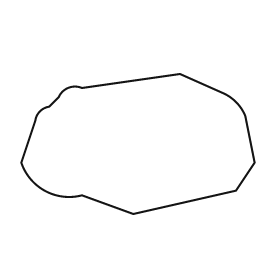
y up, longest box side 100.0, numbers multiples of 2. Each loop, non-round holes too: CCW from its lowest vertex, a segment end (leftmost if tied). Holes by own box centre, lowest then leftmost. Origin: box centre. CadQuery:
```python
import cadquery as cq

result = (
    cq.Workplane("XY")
    .moveTo(-2.0, -30.0)
    .lineTo(42.0, -20.0)
    .lineTo(50.0, -8.0)
    .lineTo(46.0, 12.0)
    .threePointArc((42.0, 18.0), (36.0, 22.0))
    .lineTo(18.0, 30.0)
    .lineTo(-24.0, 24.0)
    .threePointArc((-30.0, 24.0), (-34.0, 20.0))
    .lineTo(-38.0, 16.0)
    .threePointArc((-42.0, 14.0), (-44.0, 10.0))
    .lineTo(-50.0, -8.0)
    .threePointArc((-40.0, -20.0), (-24.0, -22.0))
    .close()
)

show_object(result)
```